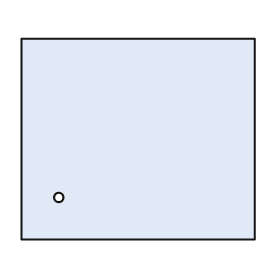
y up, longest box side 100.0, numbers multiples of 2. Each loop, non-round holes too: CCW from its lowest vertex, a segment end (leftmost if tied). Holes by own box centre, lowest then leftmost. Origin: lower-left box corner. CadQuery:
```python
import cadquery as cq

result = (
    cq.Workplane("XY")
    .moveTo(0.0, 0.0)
    .lineTo(100.0, 0.0)
    .lineTo(100.0, 86.0)
    .lineTo(0.0, 86.0)
    .close()
    .moveTo(16.0, 18.0)
    .circle(2.0)
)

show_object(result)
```